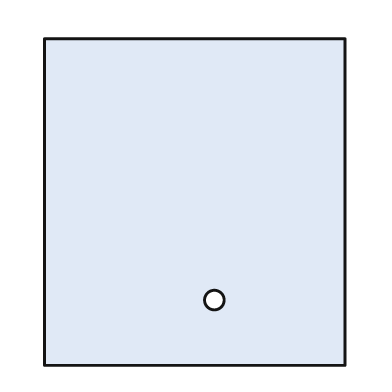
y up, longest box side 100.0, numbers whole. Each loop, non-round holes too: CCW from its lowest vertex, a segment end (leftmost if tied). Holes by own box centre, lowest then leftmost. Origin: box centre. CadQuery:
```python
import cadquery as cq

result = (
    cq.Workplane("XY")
    .moveTo(-46.0, -50.0)
    .lineTo(46.0, -50.0)
    .lineTo(46.0, 50.0)
    .lineTo(-46.0, 50.0)
    .close()
    .moveTo(6.0, -30.0)
    .circle(3.0)
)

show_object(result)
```